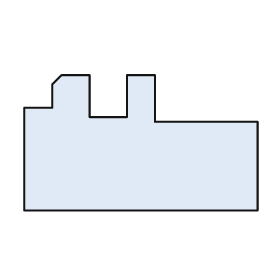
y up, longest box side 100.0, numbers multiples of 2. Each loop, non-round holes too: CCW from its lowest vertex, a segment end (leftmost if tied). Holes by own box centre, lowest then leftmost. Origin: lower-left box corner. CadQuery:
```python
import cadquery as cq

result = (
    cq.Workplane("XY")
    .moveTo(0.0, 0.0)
    .lineTo(100.0, 0.0)
    .lineTo(100.0, 38.0)
    .lineTo(56.0, 38.0)
    .lineTo(56.0, 58.0)
    .lineTo(44.0, 58.0)
    .lineTo(44.0, 40.0)
    .lineTo(28.0, 40.0)
    .lineTo(28.0, 58.0)
    .lineTo(16.0, 58.0)
    .lineTo(12.0, 54.0)
    .lineTo(12.0, 44.0)
    .lineTo(0.0, 44.0)
    .close()
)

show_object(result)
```